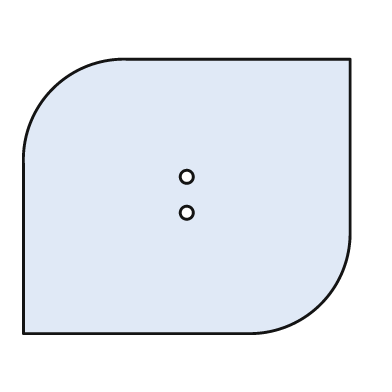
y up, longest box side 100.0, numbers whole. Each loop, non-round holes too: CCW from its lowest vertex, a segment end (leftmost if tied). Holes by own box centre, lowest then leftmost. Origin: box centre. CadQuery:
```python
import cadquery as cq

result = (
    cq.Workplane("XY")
    .moveTo(-50.0, -42.0)
    .lineTo(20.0, -42.0)
    .threePointArc((41.0, -33.0), (50.0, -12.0))
    .lineTo(50.0, 42.0)
    .lineTo(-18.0, 42.0)
    .threePointArc((-41.0, 33.0), (-50.0, 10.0))
    .close()
    .moveTo(0.0, -5.0)
    .circle(2.0)
    .moveTo(0.0, 6.0)
    .circle(2.0)
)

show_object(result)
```